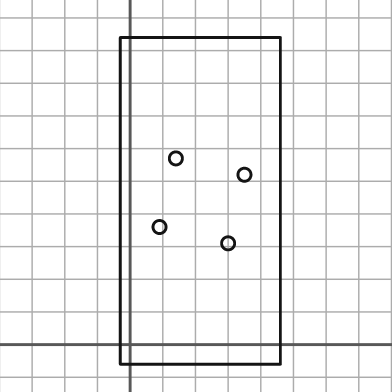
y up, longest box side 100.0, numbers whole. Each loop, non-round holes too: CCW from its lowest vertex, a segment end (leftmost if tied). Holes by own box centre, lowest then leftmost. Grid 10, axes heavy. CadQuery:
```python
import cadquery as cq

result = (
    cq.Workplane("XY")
    .moveTo(-3.0, -6.0)
    .lineTo(46.0, -6.0)
    .lineTo(46.0, 94.0)
    .lineTo(-3.0, 94.0)
    .close()
    .moveTo(30.0, 31.0)
    .circle(2.0)
    .moveTo(9.0, 36.0)
    .circle(2.0)
    .moveTo(35.0, 52.0)
    .circle(2.0)
    .moveTo(14.0, 57.0)
    .circle(2.0)
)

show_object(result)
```